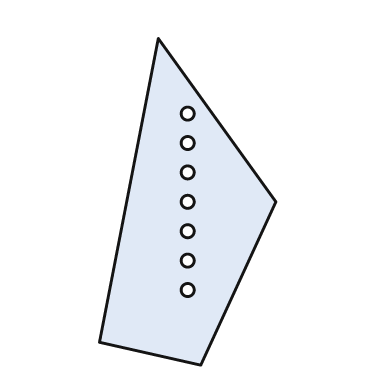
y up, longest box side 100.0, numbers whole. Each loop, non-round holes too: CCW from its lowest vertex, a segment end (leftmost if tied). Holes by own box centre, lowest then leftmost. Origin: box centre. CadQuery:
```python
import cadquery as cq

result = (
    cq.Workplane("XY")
    .moveTo(4.0, -50.0)
    .lineTo(27.0, 0.0)
    .lineTo(-9.0, 50.0)
    .lineTo(-27.0, -43.0)
    .close()
    .moveTo(0.0, -27.0)
    .circle(2.0)
    .moveTo(0.0, -18.0)
    .circle(2.0)
    .moveTo(0.0, -9.0)
    .circle(2.0)
    .moveTo(0.0, 0.0)
    .circle(2.0)
    .moveTo(0.0, 9.0)
    .circle(2.0)
    .moveTo(0.0, 18.0)
    .circle(2.0)
    .moveTo(0.0, 27.0)
    .circle(2.0)
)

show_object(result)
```